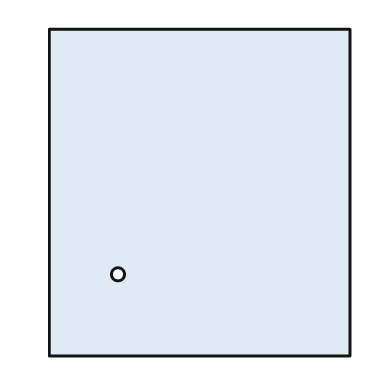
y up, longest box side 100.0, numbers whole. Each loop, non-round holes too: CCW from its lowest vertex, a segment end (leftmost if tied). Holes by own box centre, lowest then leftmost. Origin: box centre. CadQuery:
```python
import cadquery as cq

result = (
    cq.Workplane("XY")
    .moveTo(-46.0, -50.0)
    .lineTo(46.0, -50.0)
    .lineTo(46.0, 50.0)
    .lineTo(-46.0, 50.0)
    .close()
    .moveTo(-25.0, -25.0)
    .circle(2.0)
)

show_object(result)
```